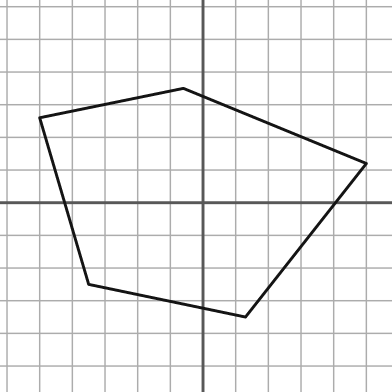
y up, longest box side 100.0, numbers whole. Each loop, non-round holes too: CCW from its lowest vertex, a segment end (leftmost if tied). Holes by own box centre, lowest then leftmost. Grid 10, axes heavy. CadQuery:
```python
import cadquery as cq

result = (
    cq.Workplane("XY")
    .moveTo(13.0, -35.0)
    .lineTo(50.0, 12.0)
    .lineTo(-6.0, 35.0)
    .lineTo(-50.0, 26.0)
    .lineTo(-35.0, -25.0)
    .close()
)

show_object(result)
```